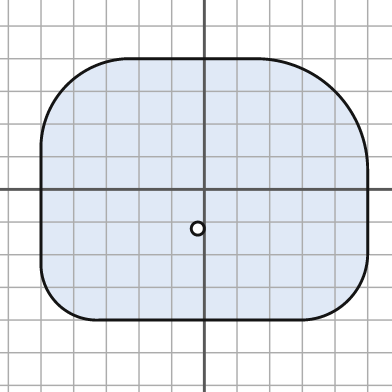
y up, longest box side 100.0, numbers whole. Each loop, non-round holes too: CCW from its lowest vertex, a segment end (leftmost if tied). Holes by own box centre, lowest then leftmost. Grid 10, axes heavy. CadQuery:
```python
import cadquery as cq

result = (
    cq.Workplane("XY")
    .moveTo(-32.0, -40.0)
    .lineTo(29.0, -40.0)
    .threePointArc((44.0, -34.0), (50.0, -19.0))
    .lineTo(50.0, 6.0)
    .threePointArc((40.0, 30.0), (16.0, 40.0))
    .lineTo(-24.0, 40.0)
    .threePointArc((-42.0, 32.0), (-50.0, 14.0))
    .lineTo(-50.0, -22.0)
    .threePointArc((-45.0, -35.0), (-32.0, -40.0))
    .close()
    .moveTo(-2.0, -12.0)
    .circle(2.0)
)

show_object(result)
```